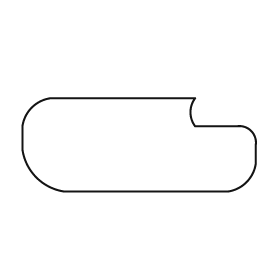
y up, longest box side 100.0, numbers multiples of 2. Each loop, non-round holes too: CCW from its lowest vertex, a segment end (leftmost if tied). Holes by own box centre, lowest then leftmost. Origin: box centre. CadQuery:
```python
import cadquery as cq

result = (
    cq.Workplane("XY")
    .moveTo(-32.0, -20.0)
    .lineTo(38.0, -20.0)
    .threePointArc((46.0, -16.0), (50.0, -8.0))
    .lineTo(50.0, 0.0)
    .threePointArc((48.0, 6.0), (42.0, 8.0))
    .lineTo(24.0, 8.0)
    .threePointArc((22.0, 14.0), (24.0, 20.0))
    .lineTo(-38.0, 20.0)
    .threePointArc((-46.0, 16.0), (-50.0, 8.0))
    .lineTo(-50.0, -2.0)
    .threePointArc((-44.0, -14.0), (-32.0, -20.0))
    .close()
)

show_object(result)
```